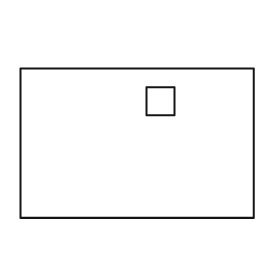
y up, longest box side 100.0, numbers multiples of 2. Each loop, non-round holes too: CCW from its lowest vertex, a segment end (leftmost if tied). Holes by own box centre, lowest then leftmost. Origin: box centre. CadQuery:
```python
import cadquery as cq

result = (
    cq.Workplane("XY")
    .moveTo(-50.0, -32.0)
    .lineTo(50.0, -32.0)
    .lineTo(50.0, 32.0)
    .lineTo(-50.0, 32.0)
    .close()
    .moveTo(4.0, 12.0)
    .lineTo(16.0, 12.0)
    .lineTo(16.0, 24.0)
    .lineTo(4.0, 24.0)
    .close()
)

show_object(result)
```